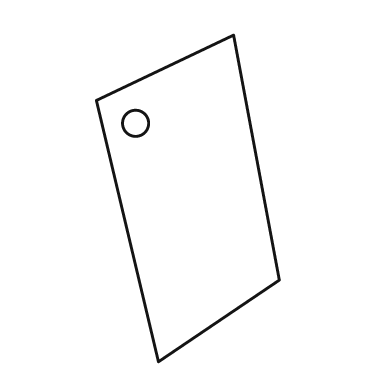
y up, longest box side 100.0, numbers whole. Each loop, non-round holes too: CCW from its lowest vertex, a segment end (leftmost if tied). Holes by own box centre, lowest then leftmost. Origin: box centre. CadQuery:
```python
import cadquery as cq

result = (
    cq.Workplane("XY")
    .moveTo(-9.0, -50.0)
    .lineTo(28.0, -25.0)
    .lineTo(14.0, 50.0)
    .lineTo(-28.0, 30.0)
    .close()
    .moveTo(-16.0, 23.0)
    .circle(4.0)
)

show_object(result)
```